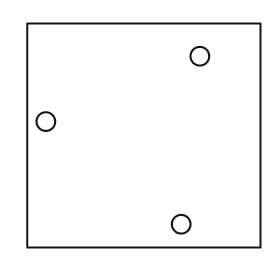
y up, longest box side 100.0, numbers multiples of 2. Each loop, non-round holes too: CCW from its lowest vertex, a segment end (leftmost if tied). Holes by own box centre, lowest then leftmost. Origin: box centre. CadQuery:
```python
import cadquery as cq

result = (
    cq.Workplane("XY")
    .moveTo(-50.0, -48.0)
    .lineTo(50.0, -48.0)
    .lineTo(50.0, 48.0)
    .lineTo(-50.0, 48.0)
    .close()
    .moveTo(16.0, -38.0)
    .circle(4.0)
    .moveTo(-42.0, 6.0)
    .circle(4.0)
    .moveTo(24.0, 34.0)
    .circle(4.0)
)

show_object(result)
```